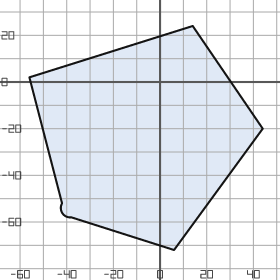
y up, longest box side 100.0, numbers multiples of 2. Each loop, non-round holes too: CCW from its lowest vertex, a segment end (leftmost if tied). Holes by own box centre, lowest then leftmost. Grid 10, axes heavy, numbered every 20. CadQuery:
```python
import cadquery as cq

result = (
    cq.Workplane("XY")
    .moveTo(6.0, -72.0)
    .lineTo(44.0, -20.0)
    .lineTo(14.0, 24.0)
    .lineTo(-56.0, 2.0)
    .lineTo(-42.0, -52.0)
    .threePointArc((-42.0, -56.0), (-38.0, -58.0))
    .close()
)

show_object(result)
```